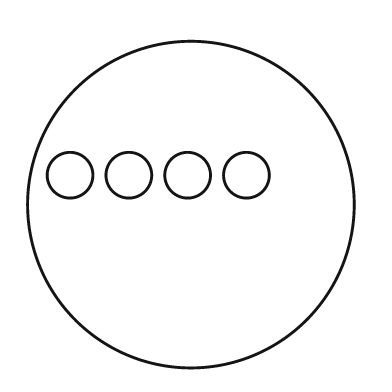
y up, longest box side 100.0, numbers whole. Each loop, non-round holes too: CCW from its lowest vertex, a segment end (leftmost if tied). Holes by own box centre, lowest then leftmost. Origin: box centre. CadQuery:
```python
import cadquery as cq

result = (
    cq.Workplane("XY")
    .moveTo(0.0, 0.0)
    .circle(50.0)
    .moveTo(-37.0, 9.0)
    .circle(7.0)
    .moveTo(-19.0, 9.0)
    .circle(7.0)
    .moveTo(-1.0, 9.0)
    .circle(7.0)
    .moveTo(17.0, 9.0)
    .circle(7.0)
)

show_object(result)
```